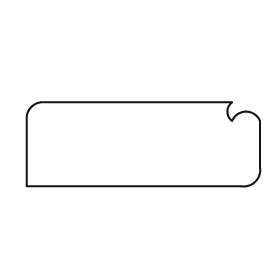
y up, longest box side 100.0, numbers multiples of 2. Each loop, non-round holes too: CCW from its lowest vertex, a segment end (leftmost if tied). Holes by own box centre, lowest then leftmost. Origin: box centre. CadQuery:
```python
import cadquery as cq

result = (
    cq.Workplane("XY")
    .moveTo(-50.0, -18.0)
    .lineTo(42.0, -18.0)
    .threePointArc((48.0, -16.0), (50.0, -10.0))
    .lineTo(50.0, 10.0)
    .threePointArc((44.0, 14.0), (38.0, 10.0))
    .threePointArc((36.0, 14.0), (38.0, 18.0))
    .lineTo(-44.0, 18.0)
    .threePointArc((-48.0, 16.0), (-50.0, 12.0))
    .close()
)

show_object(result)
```